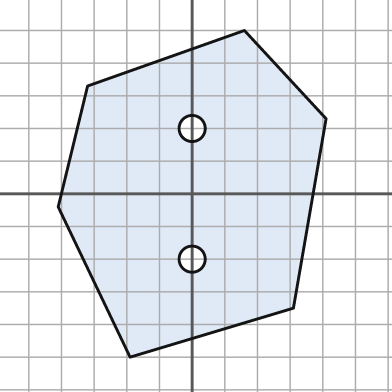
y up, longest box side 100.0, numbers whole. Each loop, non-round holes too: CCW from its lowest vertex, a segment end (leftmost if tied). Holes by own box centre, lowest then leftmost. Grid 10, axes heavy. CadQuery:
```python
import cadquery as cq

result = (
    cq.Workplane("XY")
    .moveTo(-19.0, -50.0)
    .lineTo(31.0, -35.0)
    .lineTo(41.0, 23.0)
    .lineTo(16.0, 50.0)
    .lineTo(-32.0, 33.0)
    .lineTo(-41.0, -4.0)
    .close()
    .moveTo(0.0, -20.0)
    .circle(4.0)
    .moveTo(0.0, 20.0)
    .circle(4.0)
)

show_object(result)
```